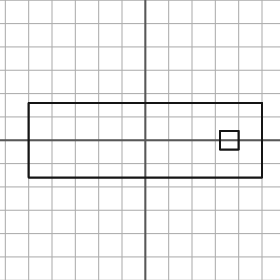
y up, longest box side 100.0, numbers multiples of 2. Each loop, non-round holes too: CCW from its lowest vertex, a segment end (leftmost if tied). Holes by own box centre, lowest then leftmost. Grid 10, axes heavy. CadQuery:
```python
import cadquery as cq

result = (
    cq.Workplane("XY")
    .moveTo(-50.0, -16.0)
    .lineTo(50.0, -16.0)
    .lineTo(50.0, 16.0)
    .lineTo(-50.0, 16.0)
    .close()
    .moveTo(32.0, -4.0)
    .lineTo(40.0, -4.0)
    .lineTo(40.0, 4.0)
    .lineTo(32.0, 4.0)
    .close()
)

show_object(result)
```